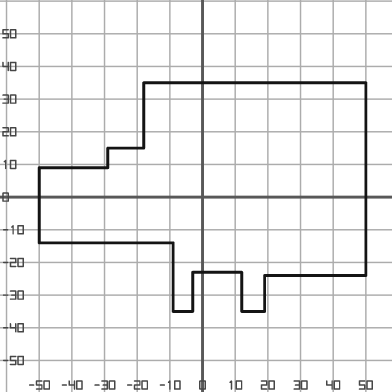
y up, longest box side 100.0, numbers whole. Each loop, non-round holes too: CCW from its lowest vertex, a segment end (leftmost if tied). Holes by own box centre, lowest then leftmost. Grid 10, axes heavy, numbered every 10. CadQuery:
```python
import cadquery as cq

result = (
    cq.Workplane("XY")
    .moveTo(-9.0, -35.0)
    .lineTo(-3.0, -35.0)
    .lineTo(-3.0, -23.0)
    .lineTo(12.0, -23.0)
    .lineTo(12.0, -35.0)
    .lineTo(19.0, -35.0)
    .lineTo(19.0, -24.0)
    .lineTo(50.0, -24.0)
    .lineTo(50.0, 35.0)
    .lineTo(-18.0, 35.0)
    .lineTo(-18.0, 15.0)
    .lineTo(-29.0, 15.0)
    .lineTo(-29.0, 9.0)
    .lineTo(-50.0, 9.0)
    .lineTo(-50.0, -14.0)
    .lineTo(-9.0, -14.0)
    .close()
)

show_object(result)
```